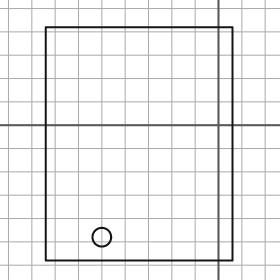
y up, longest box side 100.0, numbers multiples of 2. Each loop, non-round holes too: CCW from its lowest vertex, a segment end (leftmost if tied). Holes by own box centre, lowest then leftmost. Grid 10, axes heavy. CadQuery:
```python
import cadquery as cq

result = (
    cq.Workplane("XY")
    .moveTo(-74.0, -58.0)
    .lineTo(6.0, -58.0)
    .lineTo(6.0, 42.0)
    .lineTo(-74.0, 42.0)
    .close()
    .moveTo(-50.0, -48.0)
    .circle(4.0)
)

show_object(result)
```